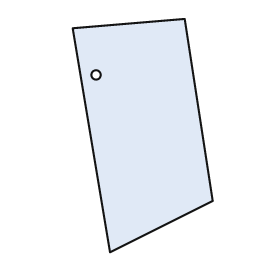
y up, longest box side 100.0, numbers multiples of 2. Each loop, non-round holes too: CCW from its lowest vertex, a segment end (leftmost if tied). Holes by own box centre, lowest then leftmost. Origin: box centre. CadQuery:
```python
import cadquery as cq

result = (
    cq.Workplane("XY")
    .moveTo(-14.0, -50.0)
    .lineTo(30.0, -28.0)
    .lineTo(18.0, 50.0)
    .lineTo(-30.0, 46.0)
    .close()
    .moveTo(-20.0, 26.0)
    .circle(2.0)
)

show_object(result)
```